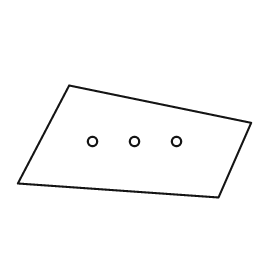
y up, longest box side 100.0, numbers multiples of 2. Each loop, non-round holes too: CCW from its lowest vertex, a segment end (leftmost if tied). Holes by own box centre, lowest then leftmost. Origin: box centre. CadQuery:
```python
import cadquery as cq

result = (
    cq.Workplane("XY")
    .moveTo(36.0, -24.0)
    .lineTo(50.0, 8.0)
    .lineTo(-28.0, 24.0)
    .lineTo(-50.0, -18.0)
    .close()
    .moveTo(-18.0, 0.0)
    .circle(2.0)
    .moveTo(0.0, 0.0)
    .circle(2.0)
    .moveTo(18.0, 0.0)
    .circle(2.0)
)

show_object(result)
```